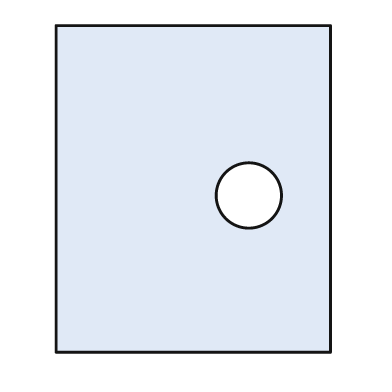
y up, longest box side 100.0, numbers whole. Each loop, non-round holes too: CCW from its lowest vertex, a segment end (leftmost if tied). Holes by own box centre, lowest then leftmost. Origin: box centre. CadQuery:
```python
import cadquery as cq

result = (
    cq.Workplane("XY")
    .moveTo(-42.0, -50.0)
    .lineTo(42.0, -50.0)
    .lineTo(42.0, 50.0)
    .lineTo(-42.0, 50.0)
    .close()
    .moveTo(17.0, -2.0)
    .circle(10.0)
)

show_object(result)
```